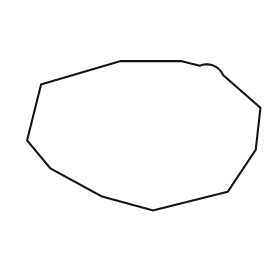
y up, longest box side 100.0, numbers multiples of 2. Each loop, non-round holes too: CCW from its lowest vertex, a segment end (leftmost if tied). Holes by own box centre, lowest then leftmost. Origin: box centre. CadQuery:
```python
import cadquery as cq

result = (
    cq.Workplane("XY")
    .moveTo(4.0, -32.0)
    .lineTo(36.0, -24.0)
    .lineTo(48.0, -6.0)
    .lineTo(50.0, 12.0)
    .lineTo(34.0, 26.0)
    .threePointArc((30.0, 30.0), (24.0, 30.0))
    .lineTo(16.0, 32.0)
    .lineTo(-10.0, 32.0)
    .lineTo(-44.0, 22.0)
    .lineTo(-50.0, -2.0)
    .lineTo(-40.0, -14.0)
    .lineTo(-18.0, -26.0)
    .close()
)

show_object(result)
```